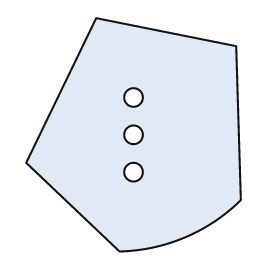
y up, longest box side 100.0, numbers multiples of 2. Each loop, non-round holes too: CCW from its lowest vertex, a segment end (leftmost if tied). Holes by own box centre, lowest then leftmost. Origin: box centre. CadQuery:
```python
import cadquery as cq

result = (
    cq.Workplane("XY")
    .moveTo(-6.0, -50.0)
    .threePointArc((22.0, -44.0), (46.0, -28.0))
    .lineTo(44.0, 38.0)
    .lineTo(-16.0, 50.0)
    .lineTo(-46.0, -12.0)
    .close()
    .moveTo(0.0, -16.0)
    .circle(4.0)
    .moveTo(0.0, 0.0)
    .circle(4.0)
    .moveTo(0.0, 16.0)
    .circle(4.0)
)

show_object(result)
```